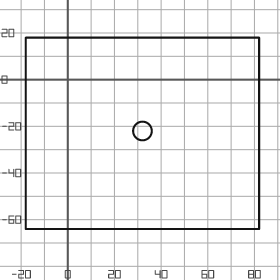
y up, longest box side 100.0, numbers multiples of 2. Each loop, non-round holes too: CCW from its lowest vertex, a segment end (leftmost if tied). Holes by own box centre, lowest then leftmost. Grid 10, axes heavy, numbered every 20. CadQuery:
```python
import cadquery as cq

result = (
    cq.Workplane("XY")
    .moveTo(-18.0, -64.0)
    .lineTo(82.0, -64.0)
    .lineTo(82.0, 18.0)
    .lineTo(-18.0, 18.0)
    .close()
    .moveTo(32.0, -22.0)
    .circle(4.0)
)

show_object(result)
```